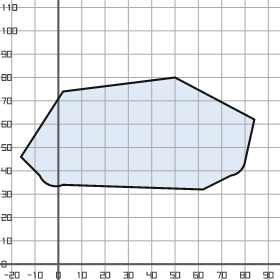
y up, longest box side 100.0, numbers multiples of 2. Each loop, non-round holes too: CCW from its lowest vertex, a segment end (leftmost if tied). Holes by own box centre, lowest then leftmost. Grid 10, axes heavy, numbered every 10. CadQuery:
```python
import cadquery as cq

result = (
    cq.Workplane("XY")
    .moveTo(62.0, 32.0)
    .lineTo(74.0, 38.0)
    .threePointArc((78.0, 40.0), (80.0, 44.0))
    .lineTo(84.0, 62.0)
    .lineTo(50.0, 80.0)
    .lineTo(2.0, 74.0)
    .lineTo(-16.0, 46.0)
    .lineTo(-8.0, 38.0)
    .threePointArc((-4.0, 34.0), (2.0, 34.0))
    .close()
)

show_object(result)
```